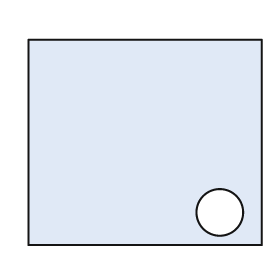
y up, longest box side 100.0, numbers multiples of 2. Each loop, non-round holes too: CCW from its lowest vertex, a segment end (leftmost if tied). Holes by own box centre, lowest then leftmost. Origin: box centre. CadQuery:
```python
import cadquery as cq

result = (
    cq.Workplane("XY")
    .moveTo(-50.0, -44.0)
    .lineTo(50.0, -44.0)
    .lineTo(50.0, 44.0)
    .lineTo(-50.0, 44.0)
    .close()
    .moveTo(32.0, -30.0)
    .circle(10.0)
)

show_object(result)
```